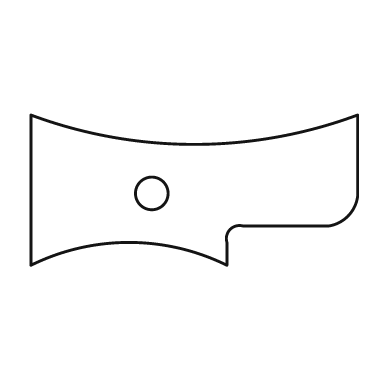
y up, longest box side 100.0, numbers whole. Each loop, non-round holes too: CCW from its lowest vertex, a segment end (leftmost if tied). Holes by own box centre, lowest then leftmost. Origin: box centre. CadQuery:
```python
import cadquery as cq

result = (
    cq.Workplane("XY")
    .moveTo(-50.0, -23.0)
    .threePointArc((-20.0, -16.0), (10.0, -23.0))
    .lineTo(10.0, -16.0)
    .threePointArc((11.0, -12.0), (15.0, -11.0))
    .lineTo(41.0, -11.0)
    .threePointArc((47.0, -8.0), (50.0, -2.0))
    .lineTo(50.0, 23.0)
    .threePointArc((0.0, 14.0), (-50.0, 23.0))
    .close()
    .moveTo(-13.0, -1.0)
    .circle(5.0)
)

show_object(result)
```